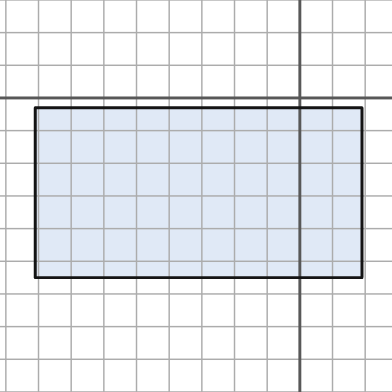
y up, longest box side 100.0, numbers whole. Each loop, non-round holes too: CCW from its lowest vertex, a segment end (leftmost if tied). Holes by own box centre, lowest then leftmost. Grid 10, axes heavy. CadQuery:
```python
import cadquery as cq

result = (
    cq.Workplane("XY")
    .moveTo(-81.0, -55.0)
    .lineTo(19.0, -55.0)
    .lineTo(19.0, -3.0)
    .lineTo(-81.0, -3.0)
    .close()
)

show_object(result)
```